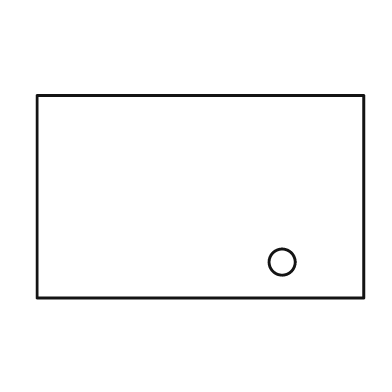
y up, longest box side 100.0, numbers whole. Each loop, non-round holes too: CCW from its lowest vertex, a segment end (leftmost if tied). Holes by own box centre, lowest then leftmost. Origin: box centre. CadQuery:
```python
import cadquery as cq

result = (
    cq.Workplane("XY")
    .moveTo(-50.0, -31.0)
    .lineTo(50.0, -31.0)
    .lineTo(50.0, 31.0)
    .lineTo(-50.0, 31.0)
    .close()
    .moveTo(25.0, -20.0)
    .circle(4.0)
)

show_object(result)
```